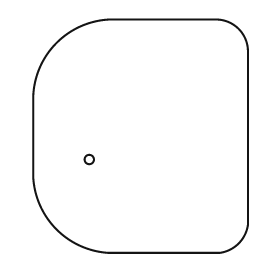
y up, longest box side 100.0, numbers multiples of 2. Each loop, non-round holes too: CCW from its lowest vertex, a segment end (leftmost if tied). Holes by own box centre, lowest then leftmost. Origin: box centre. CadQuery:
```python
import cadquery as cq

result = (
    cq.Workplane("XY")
    .moveTo(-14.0, -50.0)
    .lineTo(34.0, -50.0)
    .threePointArc((42.0, -46.0), (46.0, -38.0))
    .lineTo(46.0, 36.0)
    .threePointArc((42.0, 46.0), (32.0, 50.0))
    .lineTo(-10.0, 50.0)
    .threePointArc((-36.0, 40.0), (-46.0, 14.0))
    .lineTo(-46.0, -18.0)
    .threePointArc((-36.0, -40.0), (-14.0, -50.0))
    .close()
    .moveTo(-22.0, -10.0)
    .circle(2.0)
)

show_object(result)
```